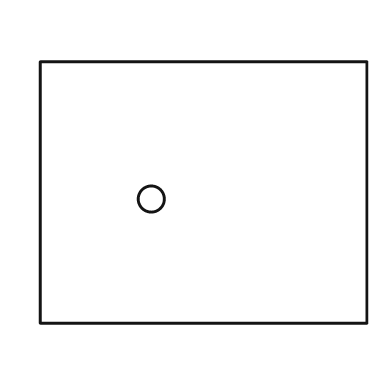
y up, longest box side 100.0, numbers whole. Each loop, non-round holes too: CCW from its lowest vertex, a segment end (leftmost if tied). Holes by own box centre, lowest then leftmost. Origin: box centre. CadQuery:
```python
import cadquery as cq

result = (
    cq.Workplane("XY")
    .moveTo(-50.0, -40.0)
    .lineTo(50.0, -40.0)
    .lineTo(50.0, 40.0)
    .lineTo(-50.0, 40.0)
    .close()
    .moveTo(-16.0, -2.0)
    .circle(4.0)
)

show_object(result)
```